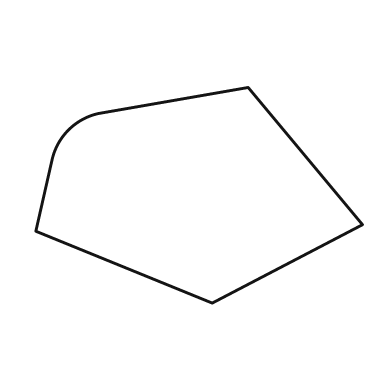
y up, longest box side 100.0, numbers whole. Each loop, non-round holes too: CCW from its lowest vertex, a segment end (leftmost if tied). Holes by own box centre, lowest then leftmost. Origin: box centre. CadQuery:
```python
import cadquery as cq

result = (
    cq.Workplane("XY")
    .moveTo(4.0, -33.0)
    .lineTo(50.0, -9.0)
    .lineTo(15.0, 33.0)
    .lineTo(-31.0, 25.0)
    .threePointArc((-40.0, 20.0), (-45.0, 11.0))
    .lineTo(-50.0, -11.0)
    .close()
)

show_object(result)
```